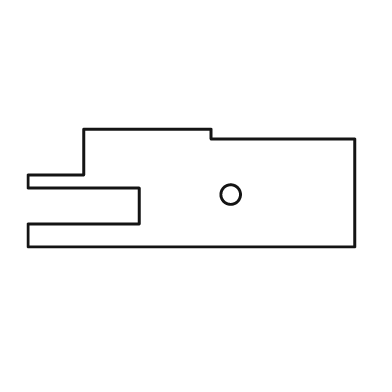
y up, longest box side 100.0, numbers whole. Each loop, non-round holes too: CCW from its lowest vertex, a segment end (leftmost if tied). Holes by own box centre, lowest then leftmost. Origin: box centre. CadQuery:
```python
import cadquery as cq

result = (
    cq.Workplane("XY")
    .moveTo(-50.0, -18.0)
    .lineTo(50.0, -18.0)
    .lineTo(50.0, 15.0)
    .lineTo(6.0, 15.0)
    .lineTo(6.0, 18.0)
    .lineTo(-33.0, 18.0)
    .lineTo(-33.0, 4.0)
    .lineTo(-50.0, 4.0)
    .lineTo(-50.0, 0.0)
    .lineTo(-16.0, 0.0)
    .lineTo(-16.0, -11.0)
    .lineTo(-50.0, -11.0)
    .close()
    .moveTo(12.0, -2.0)
    .circle(3.0)
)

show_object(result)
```